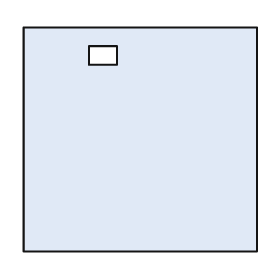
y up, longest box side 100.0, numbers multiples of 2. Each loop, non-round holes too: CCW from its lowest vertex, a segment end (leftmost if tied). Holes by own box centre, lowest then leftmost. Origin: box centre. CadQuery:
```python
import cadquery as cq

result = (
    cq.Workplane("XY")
    .moveTo(-50.0, -48.0)
    .lineTo(50.0, -48.0)
    .lineTo(50.0, 48.0)
    .lineTo(-50.0, 48.0)
    .close()
    .moveTo(-22.0, 32.0)
    .lineTo(-10.0, 32.0)
    .lineTo(-10.0, 40.0)
    .lineTo(-22.0, 40.0)
    .close()
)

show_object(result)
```